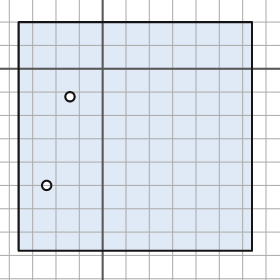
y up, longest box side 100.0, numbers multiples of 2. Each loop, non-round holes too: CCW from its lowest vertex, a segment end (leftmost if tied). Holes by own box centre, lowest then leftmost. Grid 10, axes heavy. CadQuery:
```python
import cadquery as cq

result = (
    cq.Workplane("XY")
    .moveTo(-36.0, -78.0)
    .lineTo(64.0, -78.0)
    .lineTo(64.0, 20.0)
    .lineTo(-36.0, 20.0)
    .close()
    .moveTo(-24.0, -50.0)
    .circle(2.0)
    .moveTo(-14.0, -12.0)
    .circle(2.0)
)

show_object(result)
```